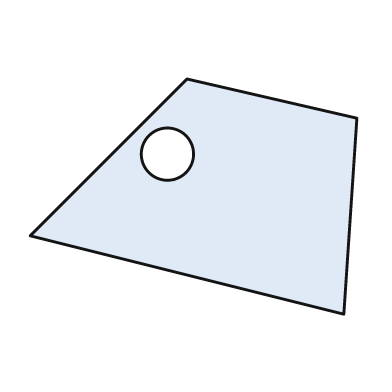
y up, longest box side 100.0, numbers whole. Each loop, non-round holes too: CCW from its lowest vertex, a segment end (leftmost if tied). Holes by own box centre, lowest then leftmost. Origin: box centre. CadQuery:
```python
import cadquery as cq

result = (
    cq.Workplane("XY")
    .moveTo(46.0, -36.0)
    .lineTo(50.0, 24.0)
    .lineTo(-2.0, 36.0)
    .lineTo(-50.0, -12.0)
    .close()
    .moveTo(-8.0, 13.0)
    .circle(8.0)
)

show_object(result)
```